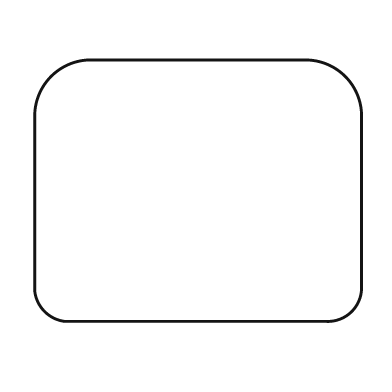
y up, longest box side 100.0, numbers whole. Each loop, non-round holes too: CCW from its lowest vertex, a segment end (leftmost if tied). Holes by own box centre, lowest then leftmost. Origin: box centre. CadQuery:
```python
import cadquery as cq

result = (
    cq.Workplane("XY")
    .moveTo(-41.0, -40.0)
    .lineTo(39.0, -40.0)
    .threePointArc((47.0, -37.0), (50.0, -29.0))
    .lineTo(50.0, 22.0)
    .threePointArc((45.0, 35.0), (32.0, 40.0))
    .lineTo(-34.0, 40.0)
    .threePointArc((-45.0, 35.0), (-50.0, 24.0))
    .lineTo(-50.0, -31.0)
    .threePointArc((-47.0, -37.0), (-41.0, -40.0))
    .close()
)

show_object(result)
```